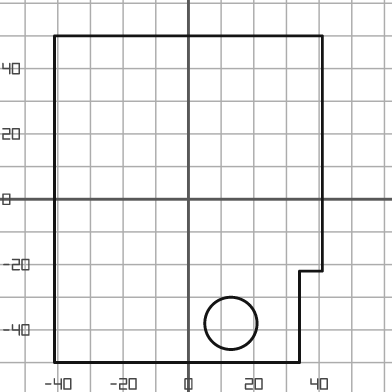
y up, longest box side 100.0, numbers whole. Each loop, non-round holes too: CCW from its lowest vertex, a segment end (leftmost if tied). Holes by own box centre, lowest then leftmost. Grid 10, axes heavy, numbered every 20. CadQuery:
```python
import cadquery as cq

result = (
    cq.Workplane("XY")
    .moveTo(-41.0, -50.0)
    .lineTo(34.0, -50.0)
    .lineTo(34.0, -22.0)
    .lineTo(41.0, -22.0)
    .lineTo(41.0, 50.0)
    .lineTo(-41.0, 50.0)
    .close()
    .moveTo(13.0, -38.0)
    .circle(8.0)
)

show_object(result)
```